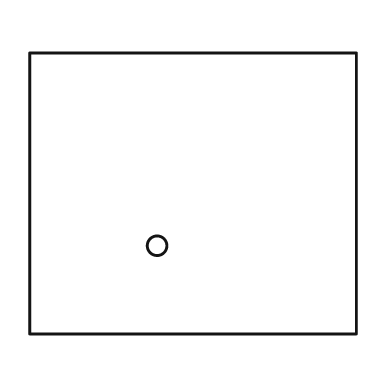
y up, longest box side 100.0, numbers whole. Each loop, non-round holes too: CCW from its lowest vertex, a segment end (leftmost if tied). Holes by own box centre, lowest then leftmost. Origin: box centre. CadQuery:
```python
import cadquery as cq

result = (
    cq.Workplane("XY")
    .moveTo(-50.0, -43.0)
    .lineTo(50.0, -43.0)
    .lineTo(50.0, 43.0)
    .lineTo(-50.0, 43.0)
    .close()
    .moveTo(-11.0, -16.0)
    .circle(3.0)
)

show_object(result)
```